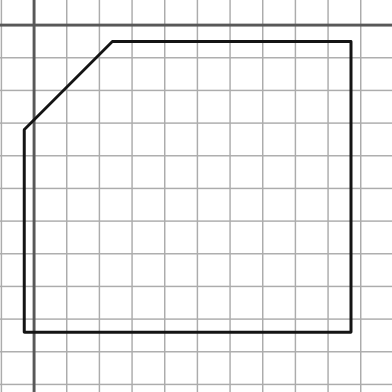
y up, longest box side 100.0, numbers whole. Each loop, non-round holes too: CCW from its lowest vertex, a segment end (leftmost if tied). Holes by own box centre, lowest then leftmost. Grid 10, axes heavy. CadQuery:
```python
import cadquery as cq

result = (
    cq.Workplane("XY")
    .moveTo(-3.0, -94.0)
    .lineTo(97.0, -94.0)
    .lineTo(97.0, -5.0)
    .lineTo(24.0, -5.0)
    .lineTo(-3.0, -32.0)
    .close()
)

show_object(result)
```